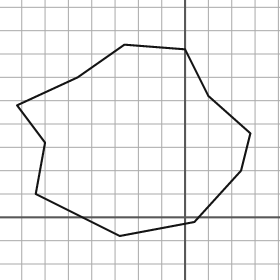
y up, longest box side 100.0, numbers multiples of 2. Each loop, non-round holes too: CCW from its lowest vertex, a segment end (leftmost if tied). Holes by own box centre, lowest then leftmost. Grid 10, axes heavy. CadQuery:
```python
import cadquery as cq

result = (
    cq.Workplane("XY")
    .moveTo(-28.0, -8.0)
    .lineTo(4.0, -2.0)
    .lineTo(24.0, 20.0)
    .lineTo(28.0, 36.0)
    .lineTo(10.0, 52.0)
    .lineTo(0.0, 72.0)
    .lineTo(-26.0, 74.0)
    .lineTo(-46.0, 60.0)
    .lineTo(-72.0, 48.0)
    .lineTo(-60.0, 32.0)
    .lineTo(-64.0, 10.0)
    .close()
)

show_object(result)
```